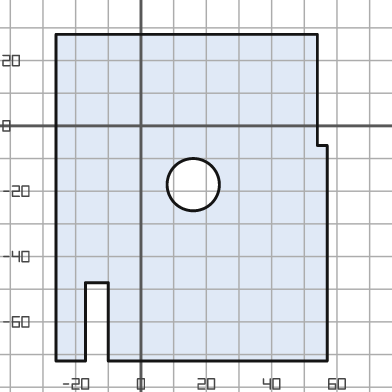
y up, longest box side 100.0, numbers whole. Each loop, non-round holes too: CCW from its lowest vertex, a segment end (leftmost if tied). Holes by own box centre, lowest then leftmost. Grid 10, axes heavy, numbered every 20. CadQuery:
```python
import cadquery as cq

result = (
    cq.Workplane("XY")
    .moveTo(-26.0, -72.0)
    .lineTo(-17.0, -72.0)
    .lineTo(-17.0, -48.0)
    .lineTo(-10.0, -48.0)
    .lineTo(-10.0, -72.0)
    .lineTo(57.0, -72.0)
    .lineTo(57.0, -6.0)
    .lineTo(54.0, -6.0)
    .lineTo(54.0, 28.0)
    .lineTo(-26.0, 28.0)
    .close()
    .moveTo(16.0, -18.0)
    .circle(8.0)
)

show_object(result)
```